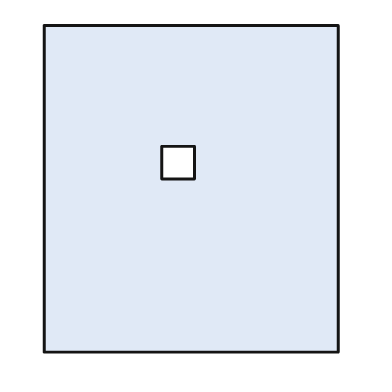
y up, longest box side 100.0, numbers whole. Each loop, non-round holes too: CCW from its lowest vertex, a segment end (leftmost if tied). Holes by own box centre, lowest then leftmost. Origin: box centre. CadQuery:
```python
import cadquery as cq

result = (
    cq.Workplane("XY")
    .moveTo(-45.0, -50.0)
    .lineTo(45.0, -50.0)
    .lineTo(45.0, 50.0)
    .lineTo(-45.0, 50.0)
    .close()
    .moveTo(-9.0, 3.0)
    .lineTo(1.0, 3.0)
    .lineTo(1.0, 13.0)
    .lineTo(-9.0, 13.0)
    .close()
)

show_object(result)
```